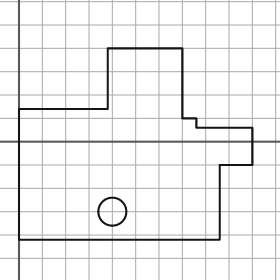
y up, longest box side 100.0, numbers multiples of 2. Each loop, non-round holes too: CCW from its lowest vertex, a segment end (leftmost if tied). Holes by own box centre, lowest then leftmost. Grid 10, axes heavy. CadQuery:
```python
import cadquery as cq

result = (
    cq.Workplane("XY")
    .moveTo(0.0, -42.0)
    .lineTo(86.0, -42.0)
    .lineTo(86.0, -10.0)
    .lineTo(100.0, -10.0)
    .lineTo(100.0, 6.0)
    .lineTo(76.0, 6.0)
    .lineTo(76.0, 10.0)
    .lineTo(70.0, 10.0)
    .lineTo(70.0, 40.0)
    .lineTo(38.0, 40.0)
    .lineTo(38.0, 14.0)
    .lineTo(0.0, 14.0)
    .close()
    .moveTo(40.0, -30.0)
    .circle(6.0)
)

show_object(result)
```